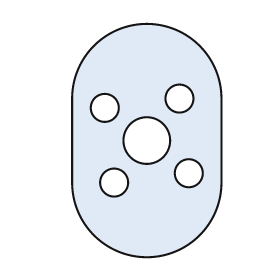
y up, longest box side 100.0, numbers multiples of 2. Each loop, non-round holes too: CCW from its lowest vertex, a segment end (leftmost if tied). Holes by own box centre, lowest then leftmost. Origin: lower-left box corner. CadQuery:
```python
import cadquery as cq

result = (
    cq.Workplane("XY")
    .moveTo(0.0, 32.0)
    .threePointArc((32.0, 0.0), (64.0, 32.0))
    .lineTo(64.0, 68.0)
    .threePointArc((32.0, 100.0), (0.0, 68.0))
    .close()
    .moveTo(18.0, 32.0)
    .circle(6.0)
    .moveTo(50.0, 36.0)
    .circle(6.0)
    .moveTo(32.0, 50.0)
    .circle(10.0)
    .moveTo(14.0, 64.0)
    .circle(6.0)
    .moveTo(46.0, 68.0)
    .circle(6.0)
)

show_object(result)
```